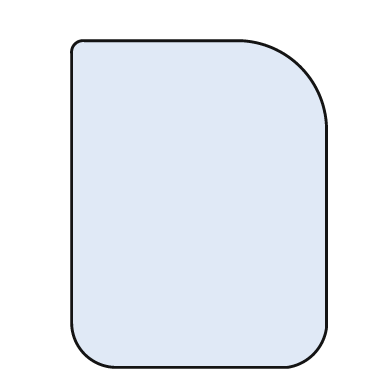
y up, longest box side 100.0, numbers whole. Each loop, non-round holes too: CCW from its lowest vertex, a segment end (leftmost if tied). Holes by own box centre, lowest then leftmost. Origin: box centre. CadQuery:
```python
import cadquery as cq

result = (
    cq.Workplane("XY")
    .moveTo(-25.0, -50.0)
    .lineTo(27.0, -50.0)
    .threePointArc((35.0, -46.0), (39.0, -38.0))
    .lineTo(39.0, 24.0)
    .threePointArc((31.0, 42.0), (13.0, 50.0))
    .lineTo(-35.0, 50.0)
    .threePointArc((-38.0, 49.0), (-39.0, 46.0))
    .lineTo(-39.0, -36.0)
    .threePointArc((-35.0, -46.0), (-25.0, -50.0))
    .close()
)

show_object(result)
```